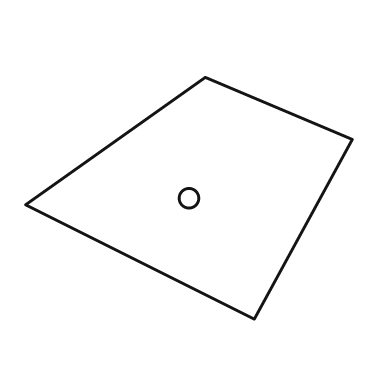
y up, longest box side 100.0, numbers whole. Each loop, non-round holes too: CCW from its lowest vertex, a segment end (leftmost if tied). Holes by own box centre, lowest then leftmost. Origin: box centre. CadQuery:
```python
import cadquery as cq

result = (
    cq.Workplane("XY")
    .moveTo(20.0, -37.0)
    .lineTo(50.0, 18.0)
    .lineTo(5.0, 37.0)
    .lineTo(-50.0, -2.0)
    .close()
    .moveTo(0.0, 0.0)
    .circle(3.0)
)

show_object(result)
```